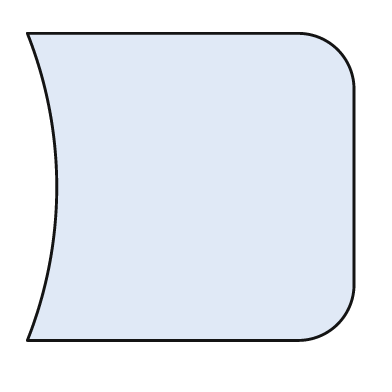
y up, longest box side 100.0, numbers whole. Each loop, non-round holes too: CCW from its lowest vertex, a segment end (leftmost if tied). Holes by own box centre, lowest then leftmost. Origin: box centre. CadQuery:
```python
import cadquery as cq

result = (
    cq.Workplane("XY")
    .moveTo(-50.0, -47.0)
    .lineTo(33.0, -47.0)
    .threePointArc((45.0, -42.0), (50.0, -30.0))
    .lineTo(50.0, 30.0)
    .threePointArc((45.0, 42.0), (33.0, 47.0))
    .lineTo(-50.0, 47.0)
    .threePointArc((-41.0, 0.0), (-50.0, -47.0))
    .close()
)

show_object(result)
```